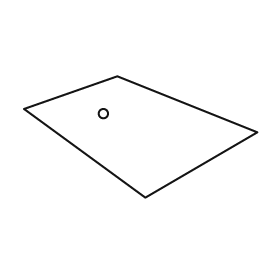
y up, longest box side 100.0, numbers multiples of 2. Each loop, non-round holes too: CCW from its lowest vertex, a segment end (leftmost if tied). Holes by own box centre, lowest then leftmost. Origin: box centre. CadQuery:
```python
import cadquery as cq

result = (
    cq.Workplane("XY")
    .moveTo(2.0, -26.0)
    .lineTo(50.0, 2.0)
    .lineTo(-10.0, 26.0)
    .lineTo(-50.0, 12.0)
    .close()
    .moveTo(-16.0, 10.0)
    .circle(2.0)
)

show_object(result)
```